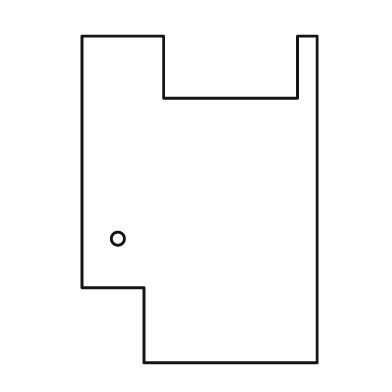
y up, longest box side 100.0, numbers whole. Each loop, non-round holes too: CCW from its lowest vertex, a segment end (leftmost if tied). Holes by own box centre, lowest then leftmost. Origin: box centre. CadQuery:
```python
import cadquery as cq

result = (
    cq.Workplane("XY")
    .moveTo(-17.0, -50.0)
    .lineTo(36.0, -50.0)
    .lineTo(36.0, 50.0)
    .lineTo(30.0, 50.0)
    .lineTo(30.0, 31.0)
    .lineTo(-11.0, 31.0)
    .lineTo(-11.0, 50.0)
    .lineTo(-36.0, 50.0)
    .lineTo(-36.0, -27.0)
    .lineTo(-17.0, -27.0)
    .close()
    .moveTo(-25.0, -12.0)
    .circle(2.0)
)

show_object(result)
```